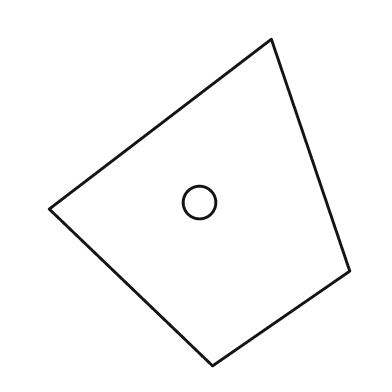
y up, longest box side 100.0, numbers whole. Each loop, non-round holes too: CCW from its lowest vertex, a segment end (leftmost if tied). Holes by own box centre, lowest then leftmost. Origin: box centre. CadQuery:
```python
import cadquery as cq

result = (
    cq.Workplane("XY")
    .moveTo(4.0, -50.0)
    .lineTo(46.0, -21.0)
    .lineTo(22.0, 50.0)
    .lineTo(-46.0, -2.0)
    .close()
    .moveTo(0.0, 0.0)
    .circle(5.0)
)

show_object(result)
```